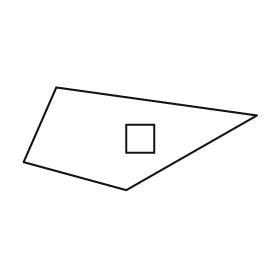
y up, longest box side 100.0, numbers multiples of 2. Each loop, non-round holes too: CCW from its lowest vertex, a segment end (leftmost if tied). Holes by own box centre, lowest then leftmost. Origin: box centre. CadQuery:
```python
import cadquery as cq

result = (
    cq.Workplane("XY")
    .moveTo(-6.0, -22.0)
    .lineTo(50.0, 10.0)
    .lineTo(-36.0, 22.0)
    .lineTo(-50.0, -10.0)
    .close()
    .moveTo(-6.0, -6.0)
    .lineTo(6.0, -6.0)
    .lineTo(6.0, 6.0)
    .lineTo(-6.0, 6.0)
    .close()
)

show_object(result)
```